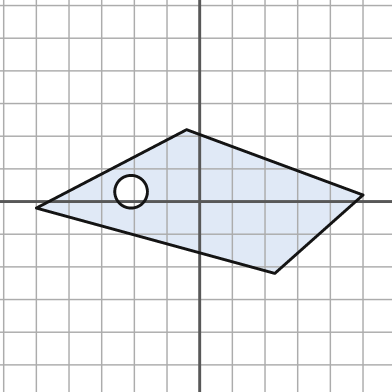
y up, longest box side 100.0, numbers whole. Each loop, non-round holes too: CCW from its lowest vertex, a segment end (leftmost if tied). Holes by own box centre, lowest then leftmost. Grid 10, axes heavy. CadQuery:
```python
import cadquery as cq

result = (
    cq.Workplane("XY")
    .moveTo(23.0, -22.0)
    .lineTo(50.0, 2.0)
    .lineTo(-4.0, 22.0)
    .lineTo(-50.0, -2.0)
    .close()
    .moveTo(-21.0, 3.0)
    .circle(5.0)
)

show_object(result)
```